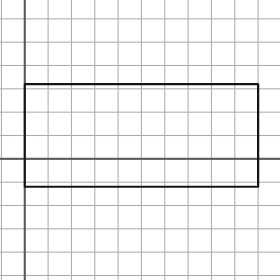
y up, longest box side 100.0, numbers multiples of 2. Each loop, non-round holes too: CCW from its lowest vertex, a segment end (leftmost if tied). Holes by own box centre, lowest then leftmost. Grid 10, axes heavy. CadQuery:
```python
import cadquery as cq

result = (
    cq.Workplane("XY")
    .moveTo(0.0, -12.0)
    .lineTo(100.0, -12.0)
    .lineTo(100.0, 32.0)
    .lineTo(0.0, 32.0)
    .close()
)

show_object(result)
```